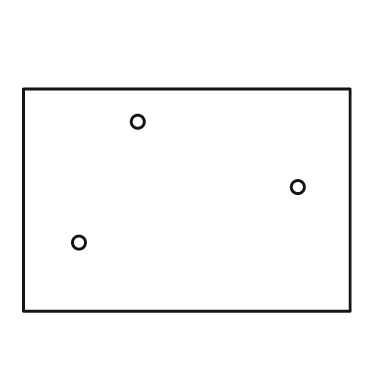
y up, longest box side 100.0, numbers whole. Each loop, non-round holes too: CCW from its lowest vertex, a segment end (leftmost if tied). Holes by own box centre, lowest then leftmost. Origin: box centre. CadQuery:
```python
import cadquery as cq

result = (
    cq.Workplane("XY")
    .moveTo(-50.0, -34.0)
    .lineTo(50.0, -34.0)
    .lineTo(50.0, 34.0)
    .lineTo(-50.0, 34.0)
    .close()
    .moveTo(-33.0, -13.0)
    .circle(2.0)
    .moveTo(34.0, 4.0)
    .circle(2.0)
    .moveTo(-15.0, 24.0)
    .circle(2.0)
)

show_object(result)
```